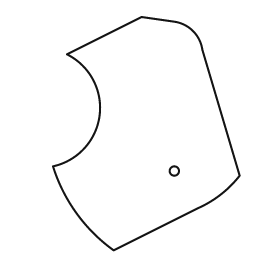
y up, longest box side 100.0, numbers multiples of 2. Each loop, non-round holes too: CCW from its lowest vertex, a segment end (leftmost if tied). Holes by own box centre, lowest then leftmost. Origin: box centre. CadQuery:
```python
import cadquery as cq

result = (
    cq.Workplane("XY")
    .moveTo(-14.0, -50.0)
    .lineTo(22.0, -32.0)
    .threePointArc((32.0, -26.0), (40.0, -18.0))
    .lineTo(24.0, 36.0)
    .threePointArc((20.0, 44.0), (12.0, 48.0))
    .lineTo(-2.0, 50.0)
    .lineTo(-34.0, 34.0)
    .threePointArc((-20.0, 8.0), (-40.0, -14.0))
    .threePointArc((-30.0, -34.0), (-14.0, -50.0))
    .close()
    .moveTo(12.0, -16.0)
    .circle(2.0)
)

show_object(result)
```